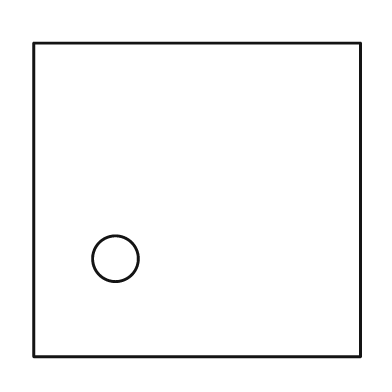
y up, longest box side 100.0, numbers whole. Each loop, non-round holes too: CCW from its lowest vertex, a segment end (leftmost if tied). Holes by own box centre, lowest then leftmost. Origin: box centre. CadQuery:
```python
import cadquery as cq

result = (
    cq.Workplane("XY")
    .moveTo(-50.0, -48.0)
    .lineTo(50.0, -48.0)
    .lineTo(50.0, 48.0)
    .lineTo(-50.0, 48.0)
    .close()
    .moveTo(-25.0, -18.0)
    .circle(7.0)
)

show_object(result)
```